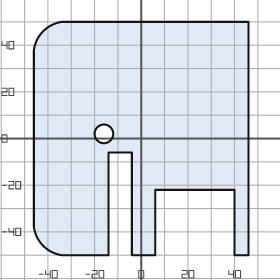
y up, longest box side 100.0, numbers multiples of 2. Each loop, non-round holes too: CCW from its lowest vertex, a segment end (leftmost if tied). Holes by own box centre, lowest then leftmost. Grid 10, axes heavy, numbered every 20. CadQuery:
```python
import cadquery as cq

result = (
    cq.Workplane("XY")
    .moveTo(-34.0, -50.0)
    .lineTo(-14.0, -50.0)
    .lineTo(-14.0, -6.0)
    .lineTo(-4.0, -6.0)
    .lineTo(-4.0, -50.0)
    .lineTo(6.0, -50.0)
    .lineTo(6.0, -22.0)
    .lineTo(40.0, -22.0)
    .lineTo(40.0, -50.0)
    .lineTo(46.0, -50.0)
    .lineTo(46.0, 50.0)
    .lineTo(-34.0, 50.0)
    .threePointArc((-42.0, 46.0), (-46.0, 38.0))
    .lineTo(-46.0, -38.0)
    .threePointArc((-42.0, -46.0), (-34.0, -50.0))
    .close()
    .moveTo(-16.0, 2.0)
    .circle(4.0)
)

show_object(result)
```